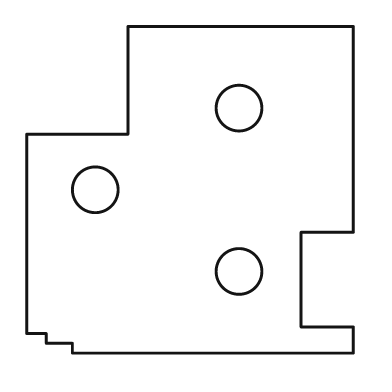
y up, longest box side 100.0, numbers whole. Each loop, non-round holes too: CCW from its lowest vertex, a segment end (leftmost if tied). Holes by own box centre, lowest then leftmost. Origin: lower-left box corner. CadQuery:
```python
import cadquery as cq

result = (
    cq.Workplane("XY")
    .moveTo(14.0, 0.0)
    .lineTo(100.0, 0.0)
    .lineTo(100.0, 8.0)
    .lineTo(84.0, 8.0)
    .lineTo(84.0, 37.0)
    .lineTo(100.0, 37.0)
    .lineTo(100.0, 100.0)
    .lineTo(31.0, 100.0)
    .lineTo(31.0, 67.0)
    .lineTo(0.0, 67.0)
    .lineTo(0.0, 6.0)
    .lineTo(6.0, 6.0)
    .lineTo(6.0, 3.0)
    .lineTo(14.0, 3.0)
    .close()
    .moveTo(65.0, 25.0)
    .circle(7.0)
    .moveTo(21.0, 50.0)
    .circle(7.0)
    .moveTo(65.0, 75.0)
    .circle(7.0)
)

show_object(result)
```